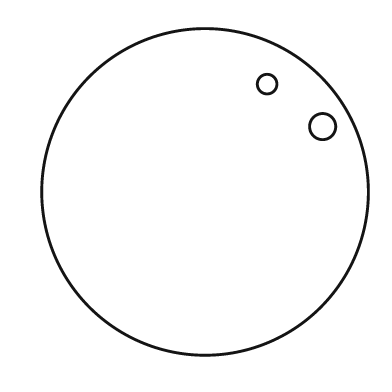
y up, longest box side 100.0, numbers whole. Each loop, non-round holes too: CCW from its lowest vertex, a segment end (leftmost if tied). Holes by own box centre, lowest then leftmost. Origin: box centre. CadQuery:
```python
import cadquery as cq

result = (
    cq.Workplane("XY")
    .moveTo(0.0, 0.0)
    .circle(50.0)
    .moveTo(36.0, 20.0)
    .circle(4.0)
    .moveTo(19.0, 33.0)
    .circle(3.0)
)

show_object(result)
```